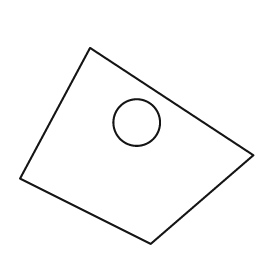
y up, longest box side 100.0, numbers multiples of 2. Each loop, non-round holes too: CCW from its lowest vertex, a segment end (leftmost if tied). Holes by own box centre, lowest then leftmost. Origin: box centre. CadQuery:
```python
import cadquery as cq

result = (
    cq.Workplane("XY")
    .moveTo(6.0, -42.0)
    .lineTo(50.0, -4.0)
    .lineTo(-20.0, 42.0)
    .lineTo(-50.0, -14.0)
    .close()
    .moveTo(0.0, 10.0)
    .circle(10.0)
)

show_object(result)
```